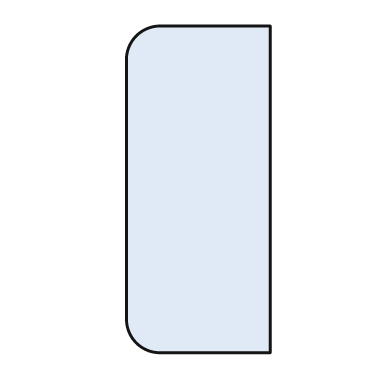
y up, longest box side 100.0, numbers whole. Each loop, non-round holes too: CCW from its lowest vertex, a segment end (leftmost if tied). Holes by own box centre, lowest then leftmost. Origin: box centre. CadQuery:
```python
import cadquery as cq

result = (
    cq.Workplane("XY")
    .moveTo(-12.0, -50.0)
    .lineTo(22.0, -50.0)
    .lineTo(22.0, 50.0)
    .lineTo(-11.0, 50.0)
    .threePointArc((-19.0, 47.0), (-22.0, 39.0))
    .lineTo(-22.0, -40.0)
    .threePointArc((-19.0, -47.0), (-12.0, -50.0))
    .close()
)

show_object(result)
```